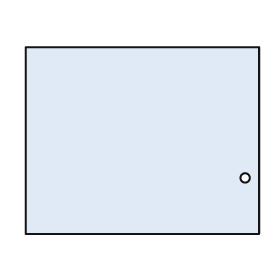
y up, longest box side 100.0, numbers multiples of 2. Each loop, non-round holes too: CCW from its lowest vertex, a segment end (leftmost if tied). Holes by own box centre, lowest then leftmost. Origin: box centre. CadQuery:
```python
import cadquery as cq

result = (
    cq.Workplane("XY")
    .moveTo(-50.0, -40.0)
    .lineTo(50.0, -40.0)
    .lineTo(50.0, 40.0)
    .lineTo(-50.0, 40.0)
    .close()
    .moveTo(44.0, -16.0)
    .circle(2.0)
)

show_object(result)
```